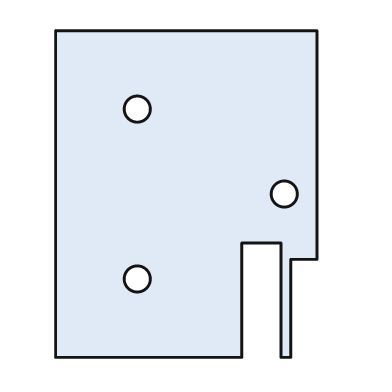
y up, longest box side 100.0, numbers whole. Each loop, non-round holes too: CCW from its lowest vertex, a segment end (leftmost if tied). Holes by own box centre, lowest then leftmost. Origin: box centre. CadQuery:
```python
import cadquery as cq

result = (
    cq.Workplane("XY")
    .moveTo(-40.0, -50.0)
    .lineTo(17.0, -50.0)
    .lineTo(17.0, -15.0)
    .lineTo(29.0, -15.0)
    .lineTo(29.0, -50.0)
    .lineTo(32.0, -50.0)
    .lineTo(32.0, -20.0)
    .lineTo(40.0, -20.0)
    .lineTo(40.0, 50.0)
    .lineTo(-40.0, 50.0)
    .close()
    .moveTo(-15.0, -26.0)
    .circle(4.0)
    .moveTo(30.0, 0.0)
    .circle(4.0)
    .moveTo(-15.0, 26.0)
    .circle(4.0)
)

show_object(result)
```